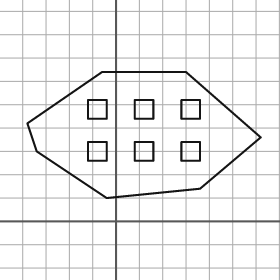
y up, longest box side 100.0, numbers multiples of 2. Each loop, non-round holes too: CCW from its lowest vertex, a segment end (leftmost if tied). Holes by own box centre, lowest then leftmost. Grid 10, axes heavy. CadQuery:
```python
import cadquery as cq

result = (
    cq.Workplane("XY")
    .moveTo(-4.0, 10.0)
    .lineTo(36.0, 14.0)
    .lineTo(62.0, 36.0)
    .lineTo(30.0, 64.0)
    .lineTo(-6.0, 64.0)
    .lineTo(-38.0, 42.0)
    .lineTo(-34.0, 30.0)
    .close()
    .moveTo(-12.0, 26.0)
    .lineTo(-4.0, 26.0)
    .lineTo(-4.0, 34.0)
    .lineTo(-12.0, 34.0)
    .close()
    .moveTo(8.0, 26.0)
    .lineTo(16.0, 26.0)
    .lineTo(16.0, 34.0)
    .lineTo(8.0, 34.0)
    .close()
    .moveTo(28.0, 26.0)
    .lineTo(36.0, 26.0)
    .lineTo(36.0, 34.0)
    .lineTo(28.0, 34.0)
    .close()
    .moveTo(-12.0, 44.0)
    .lineTo(-4.0, 44.0)
    .lineTo(-4.0, 52.0)
    .lineTo(-12.0, 52.0)
    .close()
    .moveTo(8.0, 44.0)
    .lineTo(16.0, 44.0)
    .lineTo(16.0, 52.0)
    .lineTo(8.0, 52.0)
    .close()
    .moveTo(28.0, 44.0)
    .lineTo(36.0, 44.0)
    .lineTo(36.0, 52.0)
    .lineTo(28.0, 52.0)
    .close()
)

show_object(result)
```